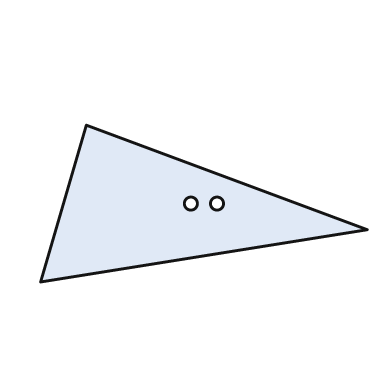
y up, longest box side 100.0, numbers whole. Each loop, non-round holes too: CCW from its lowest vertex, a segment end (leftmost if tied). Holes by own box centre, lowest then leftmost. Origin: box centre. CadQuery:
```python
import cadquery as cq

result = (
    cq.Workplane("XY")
    .moveTo(-50.0, -24.0)
    .lineTo(50.0, -8.0)
    .lineTo(-36.0, 24.0)
    .close()
    .moveTo(-4.0, 0.0)
    .circle(2.0)
    .moveTo(4.0, 0.0)
    .circle(2.0)
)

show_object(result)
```